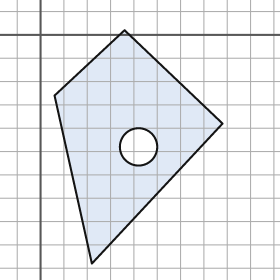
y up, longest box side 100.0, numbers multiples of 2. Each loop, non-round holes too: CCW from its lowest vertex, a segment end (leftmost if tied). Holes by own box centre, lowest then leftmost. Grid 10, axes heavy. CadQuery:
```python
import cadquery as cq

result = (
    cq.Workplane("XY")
    .moveTo(22.0, -98.0)
    .lineTo(78.0, -38.0)
    .lineTo(36.0, 2.0)
    .lineTo(6.0, -26.0)
    .close()
    .moveTo(42.0, -48.0)
    .circle(8.0)
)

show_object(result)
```